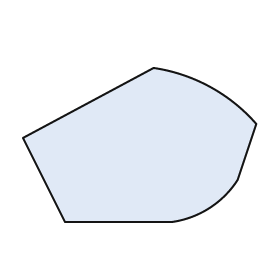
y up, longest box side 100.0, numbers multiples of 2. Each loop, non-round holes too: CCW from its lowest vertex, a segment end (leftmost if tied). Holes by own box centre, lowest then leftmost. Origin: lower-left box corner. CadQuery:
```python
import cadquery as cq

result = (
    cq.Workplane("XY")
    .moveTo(18.0, 0.0)
    .lineTo(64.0, 0.0)
    .threePointArc((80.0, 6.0), (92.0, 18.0))
    .lineTo(100.0, 42.0)
    .threePointArc((80.0, 58.0), (56.0, 66.0))
    .lineTo(0.0, 36.0)
    .close()
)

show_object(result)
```